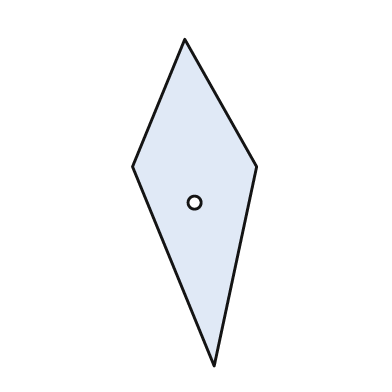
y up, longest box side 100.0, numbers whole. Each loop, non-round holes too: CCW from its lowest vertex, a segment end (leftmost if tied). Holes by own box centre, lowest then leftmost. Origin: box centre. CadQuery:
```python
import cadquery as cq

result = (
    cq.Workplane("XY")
    .moveTo(6.0, -50.0)
    .lineTo(19.0, 11.0)
    .lineTo(-3.0, 50.0)
    .lineTo(-19.0, 11.0)
    .close()
    .moveTo(0.0, 0.0)
    .circle(2.0)
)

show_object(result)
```